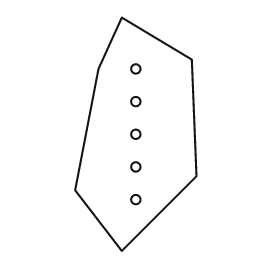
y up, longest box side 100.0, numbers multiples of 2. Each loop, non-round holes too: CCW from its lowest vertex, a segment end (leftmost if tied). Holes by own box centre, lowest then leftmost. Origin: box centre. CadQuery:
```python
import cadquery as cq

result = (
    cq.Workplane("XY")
    .moveTo(-6.0, -50.0)
    .lineTo(26.0, -18.0)
    .lineTo(24.0, 32.0)
    .lineTo(-6.0, 50.0)
    .lineTo(-16.0, 28.0)
    .lineTo(-26.0, -24.0)
    .close()
    .moveTo(0.0, -28.0)
    .circle(2.0)
    .moveTo(0.0, -14.0)
    .circle(2.0)
    .moveTo(0.0, 0.0)
    .circle(2.0)
    .moveTo(0.0, 14.0)
    .circle(2.0)
    .moveTo(0.0, 28.0)
    .circle(2.0)
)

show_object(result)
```